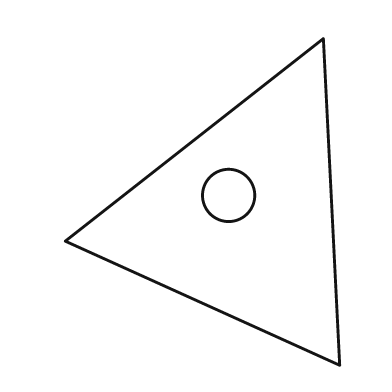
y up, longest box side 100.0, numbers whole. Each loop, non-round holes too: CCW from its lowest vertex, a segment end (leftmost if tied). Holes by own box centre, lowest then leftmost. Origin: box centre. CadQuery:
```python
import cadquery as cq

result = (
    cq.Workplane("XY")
    .moveTo(42.0, -50.0)
    .lineTo(37.0, 50.0)
    .lineTo(-42.0, -12.0)
    .close()
    .moveTo(8.0, 2.0)
    .circle(8.0)
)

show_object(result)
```